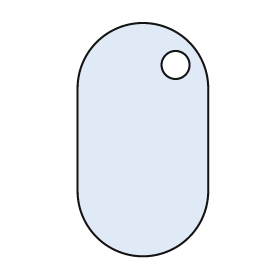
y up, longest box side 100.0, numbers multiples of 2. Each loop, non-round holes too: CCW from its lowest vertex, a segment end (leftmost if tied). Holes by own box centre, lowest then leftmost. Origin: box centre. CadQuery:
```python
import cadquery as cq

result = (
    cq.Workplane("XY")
    .moveTo(-28.0, -22.0)
    .threePointArc((0.0, -50.0), (28.0, -22.0))
    .lineTo(28.0, 22.0)
    .threePointArc((0.0, 50.0), (-28.0, 22.0))
    .close()
    .moveTo(14.0, 32.0)
    .circle(6.0)
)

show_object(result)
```